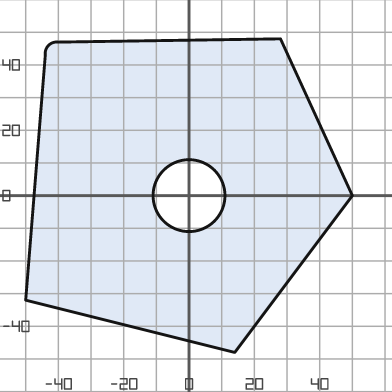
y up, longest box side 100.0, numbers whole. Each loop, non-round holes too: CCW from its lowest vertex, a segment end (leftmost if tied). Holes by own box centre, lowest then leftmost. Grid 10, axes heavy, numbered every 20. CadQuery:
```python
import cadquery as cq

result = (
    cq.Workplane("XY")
    .moveTo(14.0, -48.0)
    .lineTo(50.0, 0.0)
    .lineTo(28.0, 48.0)
    .lineTo(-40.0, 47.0)
    .threePointArc((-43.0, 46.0), (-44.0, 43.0))
    .lineTo(-50.0, -32.0)
    .close()
    .moveTo(0.0, 0.0)
    .circle(11.0)
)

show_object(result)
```